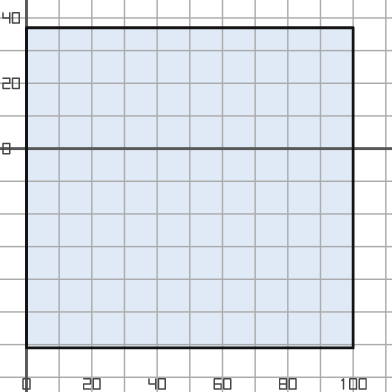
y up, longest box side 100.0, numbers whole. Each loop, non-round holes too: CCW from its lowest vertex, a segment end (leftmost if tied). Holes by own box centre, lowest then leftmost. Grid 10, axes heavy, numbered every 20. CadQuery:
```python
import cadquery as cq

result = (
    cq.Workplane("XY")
    .moveTo(0.0, -61.0)
    .lineTo(100.0, -61.0)
    .lineTo(100.0, 37.0)
    .lineTo(0.0, 37.0)
    .close()
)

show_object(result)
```